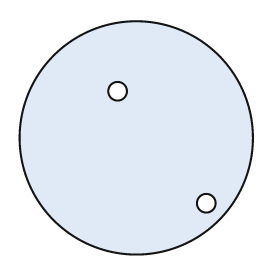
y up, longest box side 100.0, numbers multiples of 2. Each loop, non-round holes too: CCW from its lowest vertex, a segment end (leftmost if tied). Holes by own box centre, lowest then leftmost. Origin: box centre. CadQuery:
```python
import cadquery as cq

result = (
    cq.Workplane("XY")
    .moveTo(0.0, 0.0)
    .circle(50.0)
    .moveTo(30.0, -28.0)
    .circle(4.0)
    .moveTo(-8.0, 20.0)
    .circle(4.0)
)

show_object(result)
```